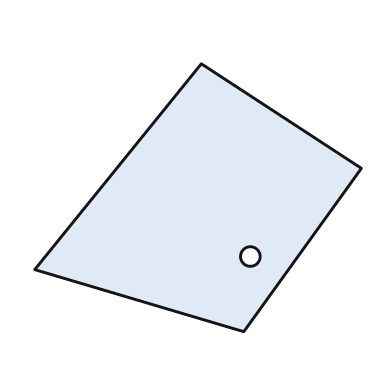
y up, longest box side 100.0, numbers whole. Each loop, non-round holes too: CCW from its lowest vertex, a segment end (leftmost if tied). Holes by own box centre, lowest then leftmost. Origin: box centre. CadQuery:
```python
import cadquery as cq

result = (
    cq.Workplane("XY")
    .moveTo(14.0, -41.0)
    .lineTo(50.0, 9.0)
    .lineTo(1.0, 41.0)
    .lineTo(-50.0, -22.0)
    .close()
    .moveTo(16.0, -18.0)
    .circle(3.0)
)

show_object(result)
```